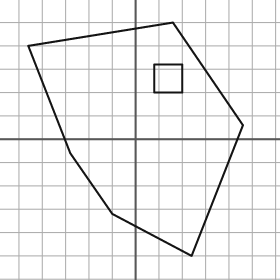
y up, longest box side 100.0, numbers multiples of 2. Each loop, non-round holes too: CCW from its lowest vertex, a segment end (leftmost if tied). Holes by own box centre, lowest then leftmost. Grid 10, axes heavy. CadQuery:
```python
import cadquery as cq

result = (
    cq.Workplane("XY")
    .moveTo(24.0, -50.0)
    .lineTo(46.0, 6.0)
    .lineTo(16.0, 50.0)
    .lineTo(-46.0, 40.0)
    .lineTo(-28.0, -6.0)
    .lineTo(-10.0, -32.0)
    .close()
    .moveTo(8.0, 20.0)
    .lineTo(20.0, 20.0)
    .lineTo(20.0, 32.0)
    .lineTo(8.0, 32.0)
    .close()
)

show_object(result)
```